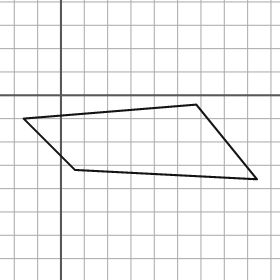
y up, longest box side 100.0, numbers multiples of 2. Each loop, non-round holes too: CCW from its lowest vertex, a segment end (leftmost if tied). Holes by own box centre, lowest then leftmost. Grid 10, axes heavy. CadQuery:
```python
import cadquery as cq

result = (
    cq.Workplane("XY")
    .moveTo(84.0, -36.0)
    .lineTo(58.0, -4.0)
    .lineTo(-16.0, -10.0)
    .lineTo(6.0, -32.0)
    .close()
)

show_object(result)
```